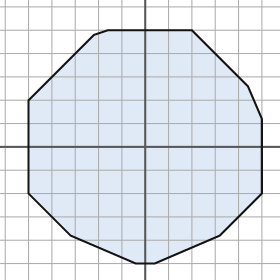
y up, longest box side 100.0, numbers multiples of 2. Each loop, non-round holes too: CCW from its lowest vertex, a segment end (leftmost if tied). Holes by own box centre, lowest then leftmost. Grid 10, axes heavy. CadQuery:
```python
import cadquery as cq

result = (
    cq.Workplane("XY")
    .moveTo(-4.0, -50.0)
    .lineTo(4.0, -50.0)
    .lineTo(32.0, -38.0)
    .lineTo(50.0, -20.0)
    .lineTo(50.0, 12.0)
    .lineTo(44.0, 26.0)
    .lineTo(20.0, 50.0)
    .lineTo(-16.0, 50.0)
    .lineTo(-22.0, 48.0)
    .lineTo(-50.0, 20.0)
    .lineTo(-50.0, -20.0)
    .lineTo(-32.0, -38.0)
    .close()
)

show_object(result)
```